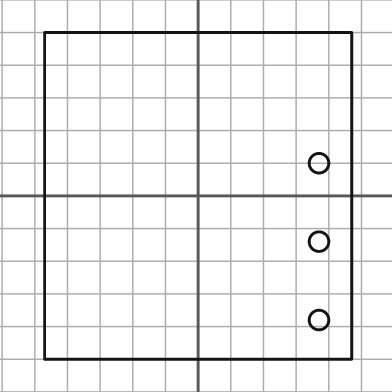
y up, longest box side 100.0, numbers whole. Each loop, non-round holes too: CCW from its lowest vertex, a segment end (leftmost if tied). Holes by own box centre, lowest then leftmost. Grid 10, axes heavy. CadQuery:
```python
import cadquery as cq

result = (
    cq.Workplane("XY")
    .moveTo(-47.0, -50.0)
    .lineTo(47.0, -50.0)
    .lineTo(47.0, 50.0)
    .lineTo(-47.0, 50.0)
    .close()
    .moveTo(37.0, -38.0)
    .circle(3.0)
    .moveTo(37.0, -14.0)
    .circle(3.0)
    .moveTo(37.0, 10.0)
    .circle(3.0)
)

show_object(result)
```